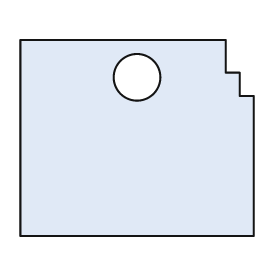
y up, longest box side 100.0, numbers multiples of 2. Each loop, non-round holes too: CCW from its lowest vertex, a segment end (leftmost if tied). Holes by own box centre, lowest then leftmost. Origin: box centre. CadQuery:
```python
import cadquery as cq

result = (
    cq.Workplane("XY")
    .moveTo(-50.0, -42.0)
    .lineTo(50.0, -42.0)
    .lineTo(50.0, 18.0)
    .lineTo(44.0, 18.0)
    .lineTo(44.0, 28.0)
    .lineTo(38.0, 28.0)
    .lineTo(38.0, 42.0)
    .lineTo(-50.0, 42.0)
    .close()
    .moveTo(0.0, 26.0)
    .circle(10.0)
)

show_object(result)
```